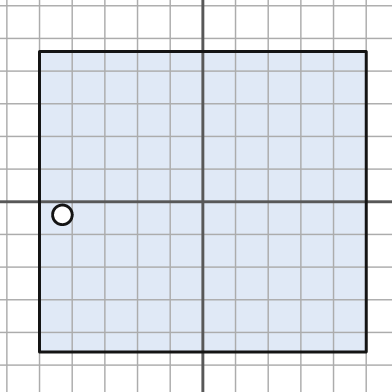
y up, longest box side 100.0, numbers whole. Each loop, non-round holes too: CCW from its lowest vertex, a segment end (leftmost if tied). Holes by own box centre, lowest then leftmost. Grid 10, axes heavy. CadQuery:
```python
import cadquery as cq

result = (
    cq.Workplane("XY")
    .moveTo(-50.0, -46.0)
    .lineTo(50.0, -46.0)
    .lineTo(50.0, 46.0)
    .lineTo(-50.0, 46.0)
    .close()
    .moveTo(-43.0, -4.0)
    .circle(3.0)
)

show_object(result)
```